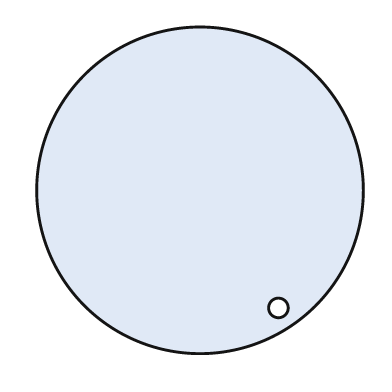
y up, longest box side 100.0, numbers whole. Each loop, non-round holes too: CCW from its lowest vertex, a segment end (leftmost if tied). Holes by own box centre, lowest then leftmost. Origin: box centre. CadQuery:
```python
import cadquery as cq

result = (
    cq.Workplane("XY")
    .moveTo(0.0, 0.0)
    .circle(50.0)
    .moveTo(24.0, -36.0)
    .circle(3.0)
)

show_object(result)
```